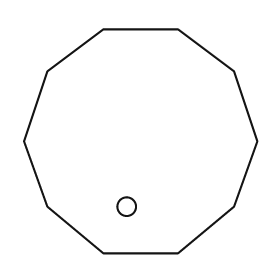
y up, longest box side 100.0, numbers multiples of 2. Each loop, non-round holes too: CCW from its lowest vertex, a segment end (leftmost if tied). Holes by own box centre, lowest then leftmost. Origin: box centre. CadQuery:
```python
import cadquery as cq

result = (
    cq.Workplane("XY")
    .moveTo(-16.0, -48.0)
    .lineTo(16.0, -48.0)
    .lineTo(40.0, -28.0)
    .lineTo(50.0, 0.0)
    .lineTo(40.0, 30.0)
    .lineTo(16.0, 48.0)
    .lineTo(-16.0, 48.0)
    .lineTo(-40.0, 30.0)
    .lineTo(-50.0, 0.0)
    .lineTo(-40.0, -28.0)
    .close()
    .moveTo(-6.0, -28.0)
    .circle(4.0)
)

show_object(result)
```